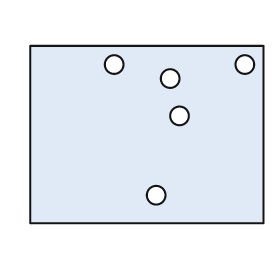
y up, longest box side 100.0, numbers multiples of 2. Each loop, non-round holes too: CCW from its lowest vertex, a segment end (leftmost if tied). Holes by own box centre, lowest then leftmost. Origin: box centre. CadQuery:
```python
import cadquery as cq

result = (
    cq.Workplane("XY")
    .moveTo(-50.0, -38.0)
    .lineTo(50.0, -38.0)
    .lineTo(50.0, 38.0)
    .lineTo(-50.0, 38.0)
    .close()
    .moveTo(4.0, -26.0)
    .circle(4.0)
    .moveTo(14.0, 8.0)
    .circle(4.0)
    .moveTo(10.0, 24.0)
    .circle(4.0)
    .moveTo(-14.0, 30.0)
    .circle(4.0)
    .moveTo(42.0, 30.0)
    .circle(4.0)
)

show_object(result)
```